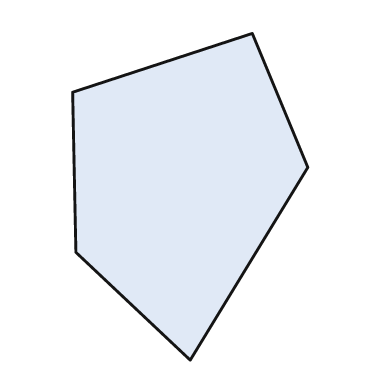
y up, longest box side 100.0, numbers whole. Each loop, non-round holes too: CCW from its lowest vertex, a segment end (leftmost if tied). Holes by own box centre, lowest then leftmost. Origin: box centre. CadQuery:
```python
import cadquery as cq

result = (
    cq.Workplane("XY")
    .moveTo(0.0, -50.0)
    .lineTo(36.0, 9.0)
    .lineTo(19.0, 50.0)
    .lineTo(-36.0, 32.0)
    .lineTo(-35.0, -17.0)
    .close()
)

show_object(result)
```